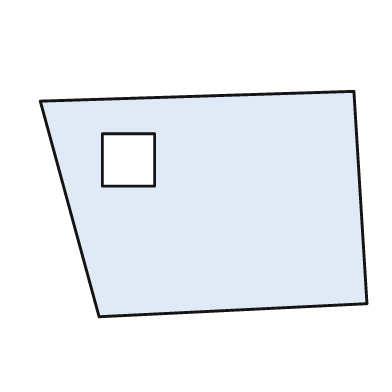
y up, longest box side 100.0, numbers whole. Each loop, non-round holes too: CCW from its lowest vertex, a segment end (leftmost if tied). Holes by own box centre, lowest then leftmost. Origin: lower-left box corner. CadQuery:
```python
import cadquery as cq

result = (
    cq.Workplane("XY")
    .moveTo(18.0, 0.0)
    .lineTo(100.0, 4.0)
    .lineTo(96.0, 69.0)
    .lineTo(0.0, 66.0)
    .close()
    .moveTo(19.0, 40.0)
    .lineTo(35.0, 40.0)
    .lineTo(35.0, 56.0)
    .lineTo(19.0, 56.0)
    .close()
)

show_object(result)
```